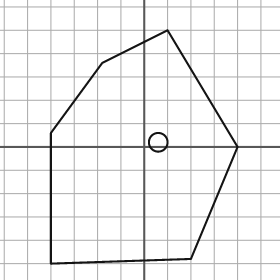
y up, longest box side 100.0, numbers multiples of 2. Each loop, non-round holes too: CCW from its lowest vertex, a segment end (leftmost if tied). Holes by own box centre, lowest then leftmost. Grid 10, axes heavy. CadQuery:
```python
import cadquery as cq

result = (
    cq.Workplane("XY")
    .moveTo(-40.0, -50.0)
    .lineTo(20.0, -48.0)
    .lineTo(40.0, 0.0)
    .lineTo(10.0, 50.0)
    .lineTo(-18.0, 36.0)
    .lineTo(-40.0, 6.0)
    .close()
    .moveTo(6.0, 2.0)
    .circle(4.0)
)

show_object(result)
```